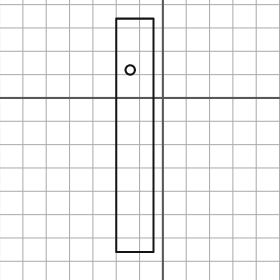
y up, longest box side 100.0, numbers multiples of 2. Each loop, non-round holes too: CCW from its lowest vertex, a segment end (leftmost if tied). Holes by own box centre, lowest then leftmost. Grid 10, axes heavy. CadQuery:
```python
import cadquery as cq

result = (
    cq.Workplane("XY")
    .moveTo(-20.0, -66.0)
    .lineTo(-4.0, -66.0)
    .lineTo(-4.0, 34.0)
    .lineTo(-20.0, 34.0)
    .close()
    .moveTo(-14.0, 12.0)
    .circle(2.0)
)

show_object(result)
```